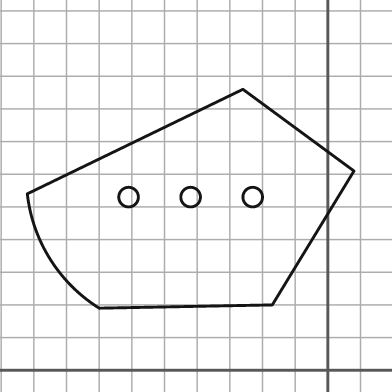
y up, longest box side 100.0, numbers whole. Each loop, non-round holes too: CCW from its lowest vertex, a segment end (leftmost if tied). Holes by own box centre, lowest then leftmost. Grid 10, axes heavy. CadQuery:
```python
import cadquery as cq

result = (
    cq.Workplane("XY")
    .moveTo(-70.0, 19.0)
    .lineTo(-17.0, 20.0)
    .lineTo(8.0, 61.0)
    .lineTo(-26.0, 86.0)
    .lineTo(-92.0, 54.0)
    .threePointArc((-85.0, 34.0), (-70.0, 19.0))
    .close()
    .moveTo(-61.0, 53.0)
    .circle(3.0)
    .moveTo(-42.0, 53.0)
    .circle(3.0)
    .moveTo(-23.0, 53.0)
    .circle(3.0)
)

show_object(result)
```